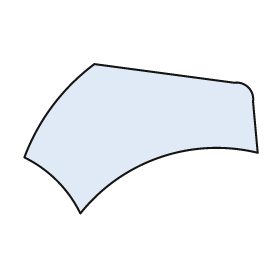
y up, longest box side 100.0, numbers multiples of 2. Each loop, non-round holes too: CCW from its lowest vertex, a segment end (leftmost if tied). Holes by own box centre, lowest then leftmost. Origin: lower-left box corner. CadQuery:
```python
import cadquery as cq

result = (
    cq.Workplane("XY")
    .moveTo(24.0, 0.0)
    .threePointArc((58.0, 24.0), (100.0, 26.0))
    .lineTo(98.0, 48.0)
    .threePointArc((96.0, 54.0), (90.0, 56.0))
    .lineTo(30.0, 64.0)
    .threePointArc((12.0, 46.0), (0.0, 24.0))
    .threePointArc((14.0, 14.0), (24.0, 0.0))
    .close()
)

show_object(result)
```